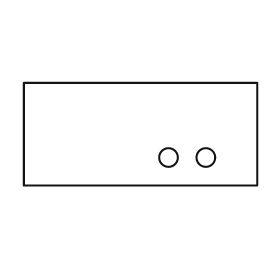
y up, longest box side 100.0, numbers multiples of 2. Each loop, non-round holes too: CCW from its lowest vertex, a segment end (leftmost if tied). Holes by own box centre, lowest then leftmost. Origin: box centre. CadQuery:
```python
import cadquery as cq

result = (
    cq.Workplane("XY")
    .moveTo(-50.0, -22.0)
    .lineTo(50.0, -22.0)
    .lineTo(50.0, 22.0)
    .lineTo(-50.0, 22.0)
    .close()
    .moveTo(12.0, -10.0)
    .circle(4.0)
    .moveTo(28.0, -10.0)
    .circle(4.0)
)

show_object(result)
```